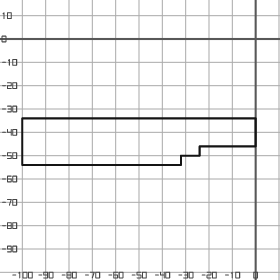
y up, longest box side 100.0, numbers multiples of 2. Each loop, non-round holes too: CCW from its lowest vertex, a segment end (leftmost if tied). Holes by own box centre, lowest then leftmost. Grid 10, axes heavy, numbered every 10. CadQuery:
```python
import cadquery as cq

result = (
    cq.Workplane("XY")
    .moveTo(-100.0, -54.0)
    .lineTo(-32.0, -54.0)
    .lineTo(-32.0, -50.0)
    .lineTo(-24.0, -50.0)
    .lineTo(-24.0, -46.0)
    .lineTo(0.0, -46.0)
    .lineTo(0.0, -34.0)
    .lineTo(-100.0, -34.0)
    .close()
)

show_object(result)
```